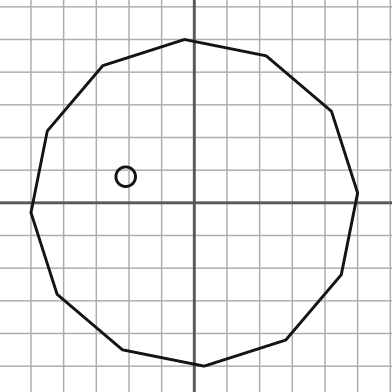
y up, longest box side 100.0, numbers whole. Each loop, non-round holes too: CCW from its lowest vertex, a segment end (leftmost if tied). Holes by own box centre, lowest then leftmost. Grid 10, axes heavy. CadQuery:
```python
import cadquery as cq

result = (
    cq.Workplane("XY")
    .moveTo(3.0, -50.0)
    .lineTo(28.0, -42.0)
    .lineTo(45.0, -22.0)
    .lineTo(50.0, 3.0)
    .lineTo(42.0, 28.0)
    .lineTo(22.0, 45.0)
    .lineTo(-3.0, 50.0)
    .lineTo(-28.0, 42.0)
    .lineTo(-45.0, 22.0)
    .lineTo(-50.0, -3.0)
    .lineTo(-42.0, -28.0)
    .lineTo(-22.0, -45.0)
    .close()
    .moveTo(-21.0, 8.0)
    .circle(3.0)
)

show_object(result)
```